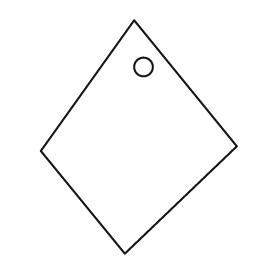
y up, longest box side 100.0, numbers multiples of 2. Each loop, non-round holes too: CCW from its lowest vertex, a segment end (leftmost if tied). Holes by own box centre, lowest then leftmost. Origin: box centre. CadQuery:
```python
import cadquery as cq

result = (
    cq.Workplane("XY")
    .moveTo(-6.0, -50.0)
    .lineTo(42.0, -4.0)
    .lineTo(-2.0, 50.0)
    .lineTo(-42.0, -6.0)
    .close()
    .moveTo(2.0, 30.0)
    .circle(4.0)
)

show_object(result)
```